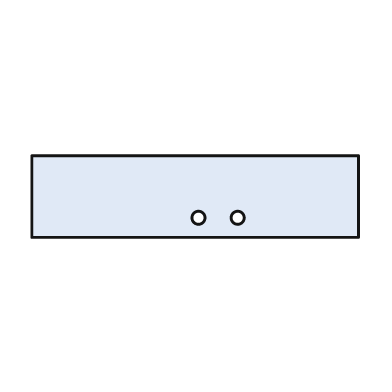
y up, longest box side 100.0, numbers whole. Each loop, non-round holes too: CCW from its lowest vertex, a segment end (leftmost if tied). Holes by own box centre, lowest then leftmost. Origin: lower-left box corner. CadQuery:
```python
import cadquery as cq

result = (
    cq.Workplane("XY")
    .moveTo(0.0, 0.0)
    .lineTo(100.0, 0.0)
    .lineTo(100.0, 25.0)
    .lineTo(0.0, 25.0)
    .close()
    .moveTo(51.0, 6.0)
    .circle(2.0)
    .moveTo(63.0, 6.0)
    .circle(2.0)
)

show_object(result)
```